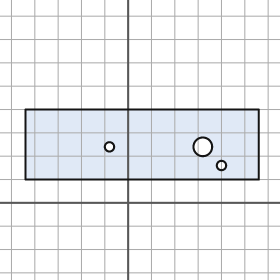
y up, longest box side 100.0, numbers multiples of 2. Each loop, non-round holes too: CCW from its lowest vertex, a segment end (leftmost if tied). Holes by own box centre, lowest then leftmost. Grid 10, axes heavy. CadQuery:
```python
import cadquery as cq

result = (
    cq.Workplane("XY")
    .moveTo(-44.0, 10.0)
    .lineTo(56.0, 10.0)
    .lineTo(56.0, 40.0)
    .lineTo(-44.0, 40.0)
    .close()
    .moveTo(40.0, 16.0)
    .circle(2.0)
    .moveTo(-8.0, 24.0)
    .circle(2.0)
    .moveTo(32.0, 24.0)
    .circle(4.0)
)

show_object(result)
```